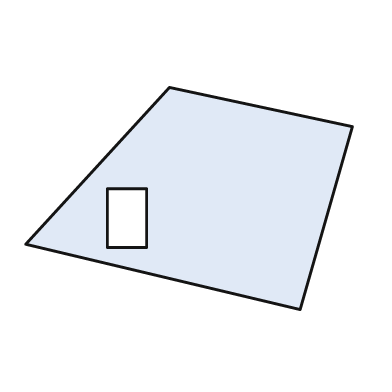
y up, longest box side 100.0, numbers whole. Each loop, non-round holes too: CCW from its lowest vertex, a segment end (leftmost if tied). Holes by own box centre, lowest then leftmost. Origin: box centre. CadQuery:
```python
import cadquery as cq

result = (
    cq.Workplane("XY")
    .moveTo(34.0, -34.0)
    .lineTo(50.0, 22.0)
    .lineTo(-6.0, 34.0)
    .lineTo(-50.0, -14.0)
    .close()
    .moveTo(-25.0, -15.0)
    .lineTo(-13.0, -15.0)
    .lineTo(-13.0, 3.0)
    .lineTo(-25.0, 3.0)
    .close()
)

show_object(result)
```